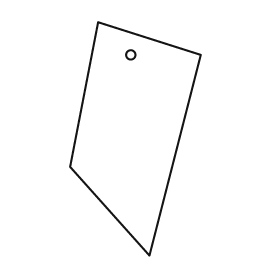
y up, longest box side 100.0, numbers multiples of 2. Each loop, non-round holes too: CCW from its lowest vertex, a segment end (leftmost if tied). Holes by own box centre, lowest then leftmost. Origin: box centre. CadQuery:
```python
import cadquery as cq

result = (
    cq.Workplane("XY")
    .moveTo(6.0, -50.0)
    .lineTo(28.0, 36.0)
    .lineTo(-16.0, 50.0)
    .lineTo(-28.0, -12.0)
    .close()
    .moveTo(-2.0, 36.0)
    .circle(2.0)
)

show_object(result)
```